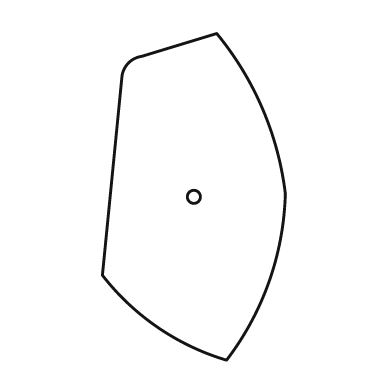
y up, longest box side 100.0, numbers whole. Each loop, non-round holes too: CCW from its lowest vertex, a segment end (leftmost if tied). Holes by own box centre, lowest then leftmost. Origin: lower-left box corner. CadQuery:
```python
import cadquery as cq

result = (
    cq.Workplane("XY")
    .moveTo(38.0, 0.0)
    .threePointArc((51.0, 24.0), (56.0, 51.0))
    .threePointArc((49.0, 77.0), (35.0, 100.0))
    .lineTo(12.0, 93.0)
    .threePointArc((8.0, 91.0), (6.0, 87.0))
    .lineTo(0.0, 26.0)
    .threePointArc((17.0, 10.0), (38.0, 0.0))
    .close()
    .moveTo(28.0, 50.0)
    .circle(2.0)
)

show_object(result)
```